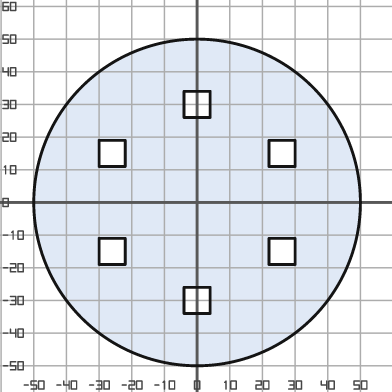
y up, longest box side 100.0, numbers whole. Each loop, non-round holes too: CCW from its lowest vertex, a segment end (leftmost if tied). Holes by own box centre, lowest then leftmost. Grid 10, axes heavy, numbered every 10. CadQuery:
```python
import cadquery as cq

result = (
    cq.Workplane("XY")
    .moveTo(0.0, 0.0)
    .circle(50.0)
    .moveTo(-4.0, -34.0)
    .lineTo(4.0, -34.0)
    .lineTo(4.0, -26.0)
    .lineTo(-4.0, -26.0)
    .close()
    .moveTo(-30.0, -19.0)
    .lineTo(-22.0, -19.0)
    .lineTo(-22.0, -11.0)
    .lineTo(-30.0, -11.0)
    .close()
    .moveTo(22.0, -19.0)
    .lineTo(30.0, -19.0)
    .lineTo(30.0, -11.0)
    .lineTo(22.0, -11.0)
    .close()
    .moveTo(-30.0, 11.0)
    .lineTo(-22.0, 11.0)
    .lineTo(-22.0, 19.0)
    .lineTo(-30.0, 19.0)
    .close()
    .moveTo(22.0, 11.0)
    .lineTo(30.0, 11.0)
    .lineTo(30.0, 19.0)
    .lineTo(22.0, 19.0)
    .close()
    .moveTo(-4.0, 26.0)
    .lineTo(4.0, 26.0)
    .lineTo(4.0, 34.0)
    .lineTo(-4.0, 34.0)
    .close()
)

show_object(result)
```